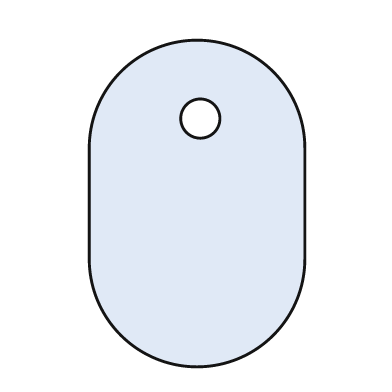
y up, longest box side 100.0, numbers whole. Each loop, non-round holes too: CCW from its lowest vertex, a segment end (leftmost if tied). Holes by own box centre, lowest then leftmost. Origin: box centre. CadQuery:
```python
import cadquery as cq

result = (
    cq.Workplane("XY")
    .moveTo(-33.0, -17.0)
    .threePointArc((0.0, -50.0), (33.0, -17.0))
    .lineTo(33.0, 17.0)
    .threePointArc((0.0, 50.0), (-33.0, 17.0))
    .close()
    .moveTo(1.0, 26.0)
    .circle(6.0)
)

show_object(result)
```